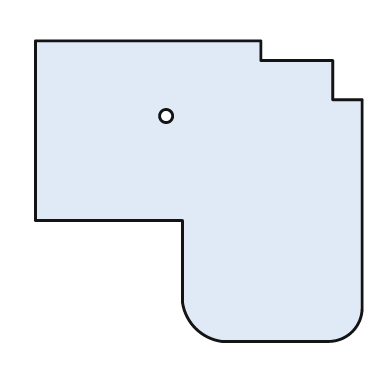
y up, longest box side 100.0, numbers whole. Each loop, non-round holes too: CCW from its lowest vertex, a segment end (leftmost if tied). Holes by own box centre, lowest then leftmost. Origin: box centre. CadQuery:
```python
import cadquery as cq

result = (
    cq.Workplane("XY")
    .moveTo(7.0, -46.0)
    .lineTo(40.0, -46.0)
    .threePointArc((47.0, -43.0), (50.0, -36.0))
    .lineTo(50.0, 28.0)
    .lineTo(41.0, 28.0)
    .lineTo(41.0, 40.0)
    .lineTo(19.0, 40.0)
    .lineTo(19.0, 46.0)
    .lineTo(-50.0, 46.0)
    .lineTo(-50.0, -9.0)
    .lineTo(-5.0, -9.0)
    .lineTo(-5.0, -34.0)
    .threePointArc((-1.0, -42.0), (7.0, -46.0))
    .close()
    .moveTo(-10.0, 23.0)
    .circle(2.0)
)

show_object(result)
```